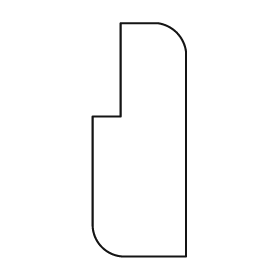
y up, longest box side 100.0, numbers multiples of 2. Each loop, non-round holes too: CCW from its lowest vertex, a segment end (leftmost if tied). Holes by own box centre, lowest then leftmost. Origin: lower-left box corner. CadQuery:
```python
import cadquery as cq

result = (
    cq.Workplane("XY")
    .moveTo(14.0, 0.0)
    .lineTo(40.0, 0.0)
    .lineTo(40.0, 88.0)
    .threePointArc((36.0, 96.0), (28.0, 100.0))
    .lineTo(12.0, 100.0)
    .lineTo(12.0, 60.0)
    .lineTo(0.0, 60.0)
    .lineTo(0.0, 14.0)
    .threePointArc((4.0, 4.0), (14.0, 0.0))
    .close()
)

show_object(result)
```